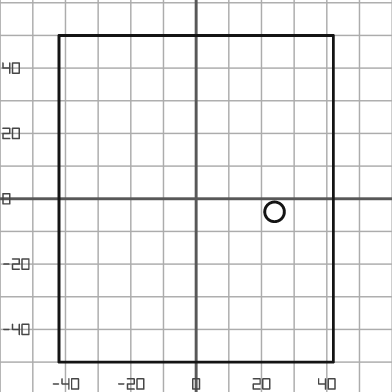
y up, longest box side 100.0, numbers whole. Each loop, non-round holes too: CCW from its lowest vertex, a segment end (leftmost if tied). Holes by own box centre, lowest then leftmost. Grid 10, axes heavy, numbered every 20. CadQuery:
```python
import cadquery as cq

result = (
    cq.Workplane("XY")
    .moveTo(-42.0, -50.0)
    .lineTo(42.0, -50.0)
    .lineTo(42.0, 50.0)
    .lineTo(-42.0, 50.0)
    .close()
    .moveTo(24.0, -4.0)
    .circle(3.0)
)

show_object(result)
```